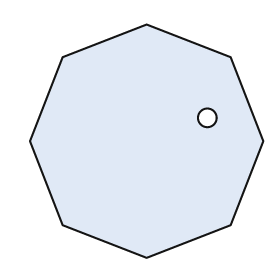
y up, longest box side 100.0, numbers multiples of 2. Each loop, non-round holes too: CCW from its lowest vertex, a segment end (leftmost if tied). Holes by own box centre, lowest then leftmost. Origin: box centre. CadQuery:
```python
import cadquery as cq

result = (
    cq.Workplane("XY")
    .moveTo(0.0, -50.0)
    .lineTo(36.0, -36.0)
    .lineTo(50.0, 0.0)
    .lineTo(36.0, 36.0)
    .lineTo(0.0, 50.0)
    .lineTo(-36.0, 36.0)
    .lineTo(-50.0, 0.0)
    .lineTo(-36.0, -36.0)
    .close()
    .moveTo(26.0, 10.0)
    .circle(4.0)
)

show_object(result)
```